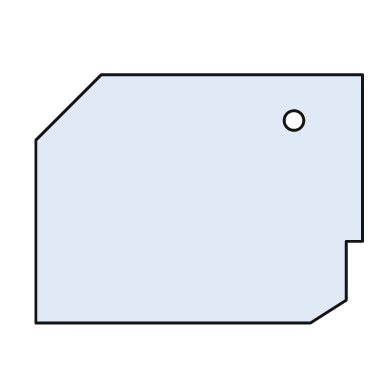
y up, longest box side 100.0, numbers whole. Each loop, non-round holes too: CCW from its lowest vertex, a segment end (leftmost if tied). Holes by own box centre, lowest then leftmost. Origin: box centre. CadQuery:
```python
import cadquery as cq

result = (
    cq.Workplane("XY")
    .moveTo(-50.0, -38.0)
    .lineTo(34.0, -38.0)
    .lineTo(45.0, -31.0)
    .lineTo(45.0, -13.0)
    .lineTo(50.0, -13.0)
    .lineTo(50.0, 38.0)
    .lineTo(-30.0, 38.0)
    .lineTo(-50.0, 18.0)
    .close()
    .moveTo(29.0, 24.0)
    .circle(3.0)
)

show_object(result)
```